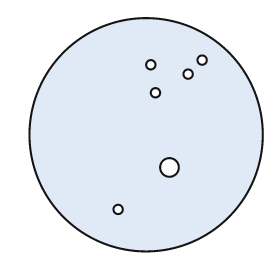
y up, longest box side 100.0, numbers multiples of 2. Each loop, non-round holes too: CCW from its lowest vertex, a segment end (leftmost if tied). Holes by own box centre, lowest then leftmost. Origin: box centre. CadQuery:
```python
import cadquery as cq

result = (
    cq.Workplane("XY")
    .moveTo(0.0, 0.0)
    .circle(50.0)
    .moveTo(-12.0, -32.0)
    .circle(2.0)
    .moveTo(10.0, -14.0)
    .circle(4.0)
    .moveTo(4.0, 18.0)
    .circle(2.0)
    .moveTo(18.0, 26.0)
    .circle(2.0)
    .moveTo(2.0, 30.0)
    .circle(2.0)
    .moveTo(24.0, 32.0)
    .circle(2.0)
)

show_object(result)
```